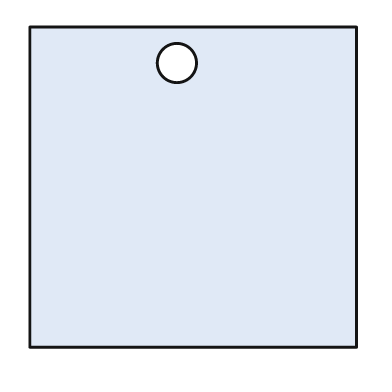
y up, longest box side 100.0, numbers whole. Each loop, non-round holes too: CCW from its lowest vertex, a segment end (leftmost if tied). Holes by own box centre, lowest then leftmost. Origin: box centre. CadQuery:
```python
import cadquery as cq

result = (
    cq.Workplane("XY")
    .moveTo(-50.0, -49.0)
    .lineTo(50.0, -49.0)
    .lineTo(50.0, 49.0)
    .lineTo(-50.0, 49.0)
    .close()
    .moveTo(-5.0, 38.0)
    .circle(6.0)
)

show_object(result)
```